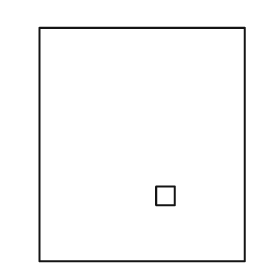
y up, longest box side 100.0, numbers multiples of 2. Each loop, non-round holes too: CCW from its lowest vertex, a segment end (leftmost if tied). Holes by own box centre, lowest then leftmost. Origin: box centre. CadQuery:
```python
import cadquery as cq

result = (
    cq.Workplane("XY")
    .moveTo(-44.0, -50.0)
    .lineTo(44.0, -50.0)
    .lineTo(44.0, 50.0)
    .lineTo(-44.0, 50.0)
    .close()
    .moveTo(6.0, -26.0)
    .lineTo(14.0, -26.0)
    .lineTo(14.0, -18.0)
    .lineTo(6.0, -18.0)
    .close()
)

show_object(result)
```